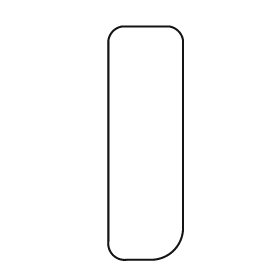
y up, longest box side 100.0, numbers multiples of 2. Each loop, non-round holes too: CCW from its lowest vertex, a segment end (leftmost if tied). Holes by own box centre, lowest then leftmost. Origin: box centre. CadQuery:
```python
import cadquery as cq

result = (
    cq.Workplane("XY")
    .moveTo(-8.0, -50.0)
    .lineTo(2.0, -50.0)
    .threePointArc((12.0, -46.0), (16.0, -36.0))
    .lineTo(16.0, 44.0)
    .threePointArc((14.0, 48.0), (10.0, 50.0))
    .lineTo(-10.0, 50.0)
    .threePointArc((-14.0, 48.0), (-16.0, 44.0))
    .lineTo(-16.0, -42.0)
    .threePointArc((-14.0, -48.0), (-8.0, -50.0))
    .close()
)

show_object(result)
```